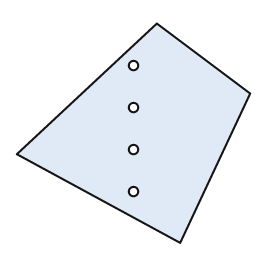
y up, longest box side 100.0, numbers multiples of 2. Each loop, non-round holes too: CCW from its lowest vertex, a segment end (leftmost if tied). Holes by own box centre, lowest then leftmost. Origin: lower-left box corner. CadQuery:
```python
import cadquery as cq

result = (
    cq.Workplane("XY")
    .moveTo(70.0, 0.0)
    .lineTo(100.0, 64.0)
    .lineTo(60.0, 94.0)
    .lineTo(0.0, 38.0)
    .close()
    .moveTo(50.0, 22.0)
    .circle(2.0)
    .moveTo(50.0, 40.0)
    .circle(2.0)
    .moveTo(50.0, 58.0)
    .circle(2.0)
    .moveTo(50.0, 76.0)
    .circle(2.0)
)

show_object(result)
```